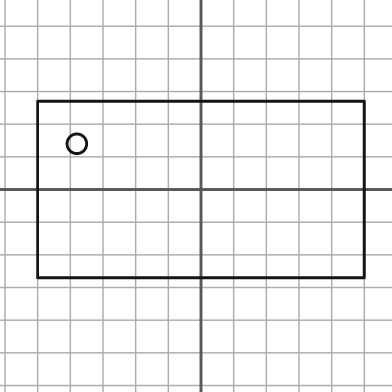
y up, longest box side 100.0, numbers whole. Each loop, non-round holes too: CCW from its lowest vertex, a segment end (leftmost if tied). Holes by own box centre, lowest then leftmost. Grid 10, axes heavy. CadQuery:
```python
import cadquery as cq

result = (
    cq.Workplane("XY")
    .moveTo(-50.0, -27.0)
    .lineTo(50.0, -27.0)
    .lineTo(50.0, 27.0)
    .lineTo(-50.0, 27.0)
    .close()
    .moveTo(-38.0, 14.0)
    .circle(3.0)
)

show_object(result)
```